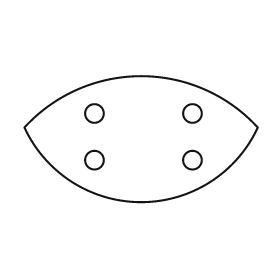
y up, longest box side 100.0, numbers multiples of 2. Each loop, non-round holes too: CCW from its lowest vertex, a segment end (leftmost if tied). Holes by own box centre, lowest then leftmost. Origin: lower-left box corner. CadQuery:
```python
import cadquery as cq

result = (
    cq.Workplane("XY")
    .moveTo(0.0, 32.0)
    .threePointArc((50.0, 0.0), (100.0, 32.0))
    .threePointArc((50.0, 54.0), (0.0, 32.0))
    .close()
    .moveTo(30.0, 18.0)
    .circle(4.0)
    .moveTo(72.0, 18.0)
    .circle(4.0)
    .moveTo(30.0, 38.0)
    .circle(4.0)
    .moveTo(72.0, 38.0)
    .circle(4.0)
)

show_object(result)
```